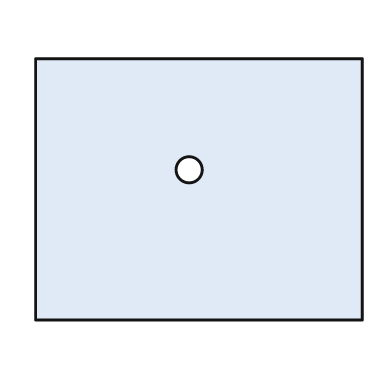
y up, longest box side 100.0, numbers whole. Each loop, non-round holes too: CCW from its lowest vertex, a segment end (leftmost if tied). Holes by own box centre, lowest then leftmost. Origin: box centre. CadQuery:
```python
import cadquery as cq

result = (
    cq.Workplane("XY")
    .moveTo(-50.0, -40.0)
    .lineTo(50.0, -40.0)
    .lineTo(50.0, 40.0)
    .lineTo(-50.0, 40.0)
    .close()
    .moveTo(-3.0, 6.0)
    .circle(4.0)
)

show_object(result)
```